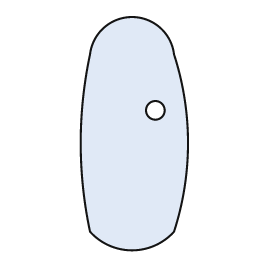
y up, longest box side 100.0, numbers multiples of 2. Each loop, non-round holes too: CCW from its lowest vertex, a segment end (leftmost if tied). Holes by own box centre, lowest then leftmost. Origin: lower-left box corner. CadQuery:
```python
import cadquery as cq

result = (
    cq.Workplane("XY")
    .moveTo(4.0, 8.0)
    .threePointArc((22.0, 0.0), (40.0, 8.0))
    .threePointArc((46.0, 46.0), (40.0, 84.0))
    .threePointArc((22.0, 100.0), (4.0, 84.0))
    .threePointArc((0.0, 46.0), (4.0, 8.0))
    .close()
    .moveTo(32.0, 60.0)
    .circle(4.0)
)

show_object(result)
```